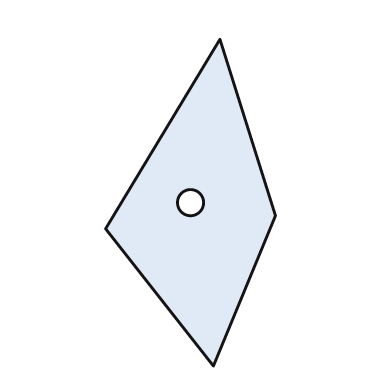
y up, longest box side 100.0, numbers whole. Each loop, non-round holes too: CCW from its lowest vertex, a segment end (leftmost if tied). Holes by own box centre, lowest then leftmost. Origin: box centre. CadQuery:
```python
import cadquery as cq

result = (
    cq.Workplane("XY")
    .moveTo(7.0, -50.0)
    .lineTo(26.0, -4.0)
    .lineTo(9.0, 50.0)
    .lineTo(-26.0, -8.0)
    .close()
    .moveTo(0.0, 0.0)
    .circle(4.0)
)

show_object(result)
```